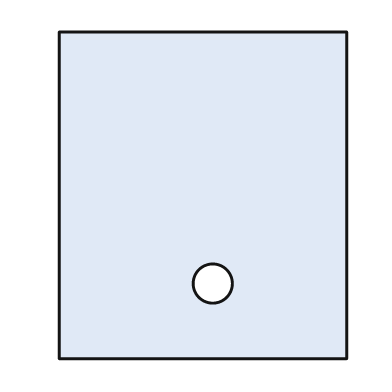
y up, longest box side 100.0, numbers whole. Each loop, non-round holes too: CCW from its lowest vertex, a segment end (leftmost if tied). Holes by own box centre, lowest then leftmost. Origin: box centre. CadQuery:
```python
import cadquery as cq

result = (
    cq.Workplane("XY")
    .moveTo(-44.0, -50.0)
    .lineTo(44.0, -50.0)
    .lineTo(44.0, 50.0)
    .lineTo(-44.0, 50.0)
    .close()
    .moveTo(3.0, -27.0)
    .circle(6.0)
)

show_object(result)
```